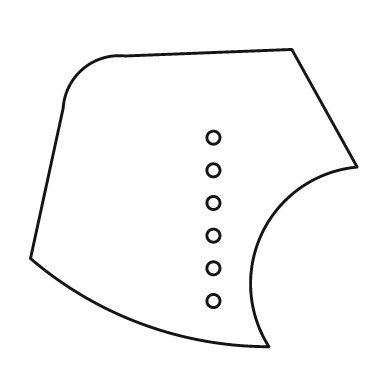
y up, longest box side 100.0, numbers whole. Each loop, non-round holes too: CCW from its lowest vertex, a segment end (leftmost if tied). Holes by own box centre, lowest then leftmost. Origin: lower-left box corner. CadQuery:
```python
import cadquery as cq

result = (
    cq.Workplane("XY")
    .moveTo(73.0, 0.0)
    .threePointArc((71.0, 35.0), (100.0, 55.0))
    .lineTo(80.0, 91.0)
    .lineTo(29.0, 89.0)
    .threePointArc((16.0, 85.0), (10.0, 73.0))
    .lineTo(0.0, 27.0)
    .threePointArc((34.0, 7.0), (73.0, 0.0))
    .close()
    .moveTo(56.0, 14.0)
    .circle(2.0)
    .moveTo(56.0, 24.0)
    .circle(2.0)
    .moveTo(56.0, 34.0)
    .circle(2.0)
    .moveTo(56.0, 44.0)
    .circle(2.0)
    .moveTo(56.0, 54.0)
    .circle(2.0)
    .moveTo(56.0, 64.0)
    .circle(2.0)
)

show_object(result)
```